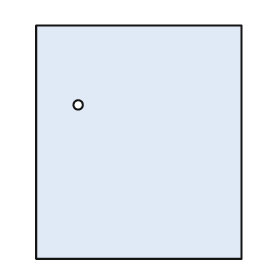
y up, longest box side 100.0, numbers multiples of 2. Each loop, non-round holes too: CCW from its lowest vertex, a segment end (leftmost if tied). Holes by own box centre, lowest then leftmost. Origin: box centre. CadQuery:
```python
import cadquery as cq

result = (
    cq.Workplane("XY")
    .moveTo(-44.0, -50.0)
    .lineTo(44.0, -50.0)
    .lineTo(44.0, 50.0)
    .lineTo(-44.0, 50.0)
    .close()
    .moveTo(-26.0, 16.0)
    .circle(2.0)
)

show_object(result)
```